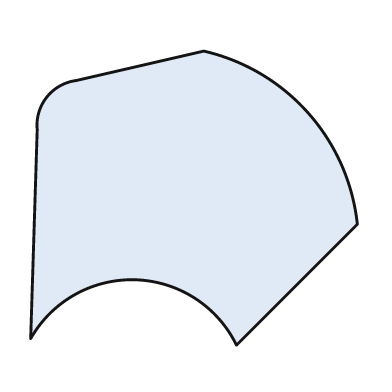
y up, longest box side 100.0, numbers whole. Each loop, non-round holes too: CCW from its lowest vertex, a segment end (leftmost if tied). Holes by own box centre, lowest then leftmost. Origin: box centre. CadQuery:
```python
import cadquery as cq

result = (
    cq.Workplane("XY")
    .moveTo(13.0, -45.0)
    .lineTo(50.0, -8.0)
    .threePointArc((35.0, 26.0), (3.0, 45.0))
    .lineTo(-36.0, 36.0)
    .threePointArc((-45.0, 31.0), (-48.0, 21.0))
    .lineTo(-50.0, -43.0)
    .threePointArc((-18.0, -25.0), (13.0, -45.0))
    .close()
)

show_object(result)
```